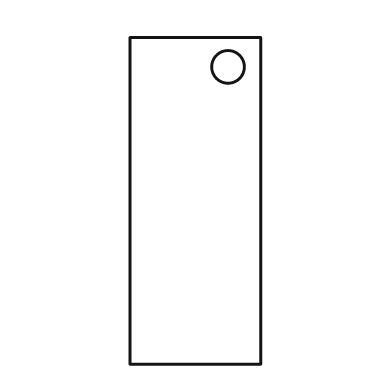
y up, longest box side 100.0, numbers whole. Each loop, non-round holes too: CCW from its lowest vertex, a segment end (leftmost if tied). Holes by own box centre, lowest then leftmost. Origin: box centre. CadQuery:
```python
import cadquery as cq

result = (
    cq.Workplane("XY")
    .moveTo(-20.0, -50.0)
    .lineTo(20.0, -50.0)
    .lineTo(20.0, 50.0)
    .lineTo(-20.0, 50.0)
    .close()
    .moveTo(10.0, 41.0)
    .circle(5.0)
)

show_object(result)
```